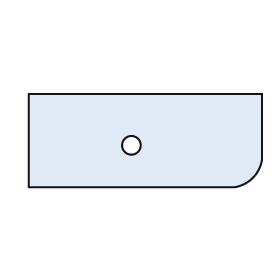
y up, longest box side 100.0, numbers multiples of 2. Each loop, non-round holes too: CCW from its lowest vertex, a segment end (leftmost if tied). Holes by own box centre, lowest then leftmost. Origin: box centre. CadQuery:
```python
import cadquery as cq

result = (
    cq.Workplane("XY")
    .moveTo(-50.0, -20.0)
    .lineTo(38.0, -20.0)
    .threePointArc((46.0, -16.0), (50.0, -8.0))
    .lineTo(50.0, 20.0)
    .lineTo(-50.0, 20.0)
    .close()
    .moveTo(-6.0, -2.0)
    .circle(4.0)
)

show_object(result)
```